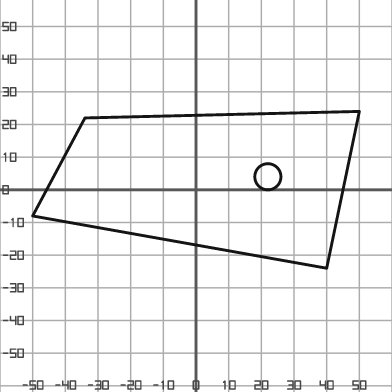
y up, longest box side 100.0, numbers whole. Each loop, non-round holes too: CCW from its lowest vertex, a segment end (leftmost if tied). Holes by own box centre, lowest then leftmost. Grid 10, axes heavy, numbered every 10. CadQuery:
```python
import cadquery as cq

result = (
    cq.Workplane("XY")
    .moveTo(40.0, -24.0)
    .lineTo(50.0, 24.0)
    .lineTo(-34.0, 22.0)
    .lineTo(-50.0, -8.0)
    .close()
    .moveTo(22.0, 4.0)
    .circle(4.0)
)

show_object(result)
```